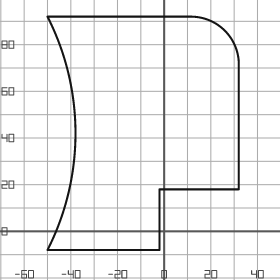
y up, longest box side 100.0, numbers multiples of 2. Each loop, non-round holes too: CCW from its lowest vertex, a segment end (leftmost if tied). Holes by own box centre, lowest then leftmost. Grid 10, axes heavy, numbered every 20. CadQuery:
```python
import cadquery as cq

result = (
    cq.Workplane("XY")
    .moveTo(-50.0, -8.0)
    .lineTo(-2.0, -8.0)
    .lineTo(-2.0, 18.0)
    .lineTo(32.0, 18.0)
    .lineTo(32.0, 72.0)
    .threePointArc((26.0, 86.0), (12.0, 92.0))
    .lineTo(-50.0, 92.0)
    .threePointArc((-38.0, 42.0), (-50.0, -8.0))
    .close()
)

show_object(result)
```